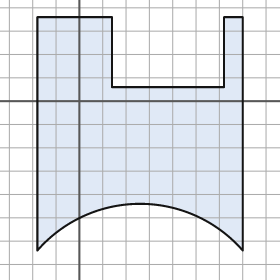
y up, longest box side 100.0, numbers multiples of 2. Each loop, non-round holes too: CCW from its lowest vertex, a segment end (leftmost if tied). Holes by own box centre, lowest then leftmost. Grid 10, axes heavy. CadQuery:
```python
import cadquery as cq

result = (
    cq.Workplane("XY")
    .moveTo(-18.0, -64.0)
    .threePointArc((26.0, -44.0), (70.0, -64.0))
    .lineTo(70.0, 36.0)
    .lineTo(62.0, 36.0)
    .lineTo(62.0, 6.0)
    .lineTo(14.0, 6.0)
    .lineTo(14.0, 36.0)
    .lineTo(-18.0, 36.0)
    .close()
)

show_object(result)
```